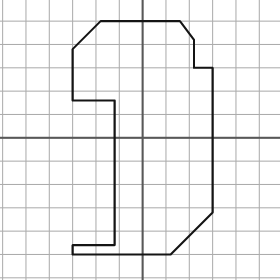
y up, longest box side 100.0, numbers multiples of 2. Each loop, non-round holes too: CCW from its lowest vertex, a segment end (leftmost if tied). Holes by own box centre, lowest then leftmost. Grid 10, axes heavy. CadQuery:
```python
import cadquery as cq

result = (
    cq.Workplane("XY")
    .moveTo(-30.0, -50.0)
    .lineTo(12.0, -50.0)
    .lineTo(30.0, -32.0)
    .lineTo(30.0, 30.0)
    .lineTo(22.0, 30.0)
    .lineTo(22.0, 42.0)
    .lineTo(16.0, 50.0)
    .lineTo(-18.0, 50.0)
    .lineTo(-30.0, 38.0)
    .lineTo(-30.0, 16.0)
    .lineTo(-12.0, 16.0)
    .lineTo(-12.0, -46.0)
    .lineTo(-30.0, -46.0)
    .close()
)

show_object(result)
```